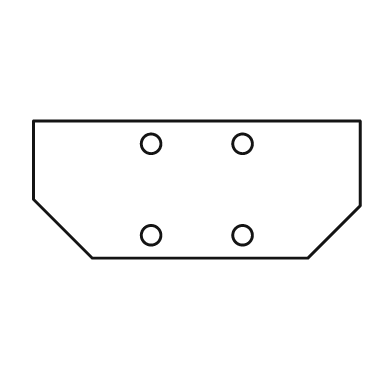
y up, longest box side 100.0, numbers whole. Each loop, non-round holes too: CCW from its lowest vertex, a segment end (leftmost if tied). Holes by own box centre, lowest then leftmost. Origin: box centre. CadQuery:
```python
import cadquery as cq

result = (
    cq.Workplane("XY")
    .moveTo(-32.0, -21.0)
    .lineTo(34.0, -21.0)
    .lineTo(50.0, -5.0)
    .lineTo(50.0, 21.0)
    .lineTo(-50.0, 21.0)
    .lineTo(-50.0, -3.0)
    .close()
    .moveTo(-14.0, -14.0)
    .circle(3.0)
    .moveTo(14.0, -14.0)
    .circle(3.0)
    .moveTo(-14.0, 14.0)
    .circle(3.0)
    .moveTo(14.0, 14.0)
    .circle(3.0)
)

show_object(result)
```